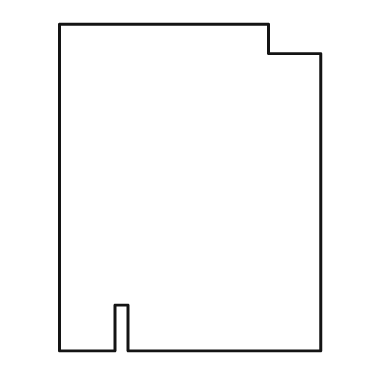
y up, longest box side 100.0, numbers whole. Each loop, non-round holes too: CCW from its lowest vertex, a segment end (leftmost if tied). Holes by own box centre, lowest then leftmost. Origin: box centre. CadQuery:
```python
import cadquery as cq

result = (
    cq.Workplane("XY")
    .moveTo(-40.0, -50.0)
    .lineTo(-23.0, -50.0)
    .lineTo(-23.0, -36.0)
    .lineTo(-19.0, -36.0)
    .lineTo(-19.0, -50.0)
    .lineTo(40.0, -50.0)
    .lineTo(40.0, 41.0)
    .lineTo(24.0, 41.0)
    .lineTo(24.0, 50.0)
    .lineTo(-40.0, 50.0)
    .close()
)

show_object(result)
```